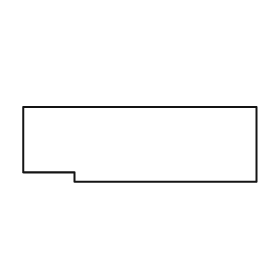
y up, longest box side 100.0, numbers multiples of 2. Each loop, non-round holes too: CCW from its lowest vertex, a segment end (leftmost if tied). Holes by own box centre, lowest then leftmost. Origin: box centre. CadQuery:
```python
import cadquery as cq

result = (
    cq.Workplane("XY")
    .moveTo(-28.0, -16.0)
    .lineTo(50.0, -16.0)
    .lineTo(50.0, 16.0)
    .lineTo(-50.0, 16.0)
    .lineTo(-50.0, -12.0)
    .lineTo(-28.0, -12.0)
    .close()
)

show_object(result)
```